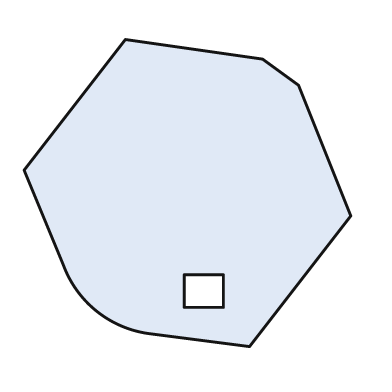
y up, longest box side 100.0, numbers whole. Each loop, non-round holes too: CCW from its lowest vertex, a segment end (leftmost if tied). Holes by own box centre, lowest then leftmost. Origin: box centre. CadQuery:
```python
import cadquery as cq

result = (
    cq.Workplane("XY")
    .moveTo(19.0, -47.0)
    .lineTo(50.0, -7.0)
    .lineTo(34.0, 33.0)
    .lineTo(23.0, 41.0)
    .lineTo(-19.0, 47.0)
    .lineTo(-50.0, 7.0)
    .lineTo(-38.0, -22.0)
    .threePointArc((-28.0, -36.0), (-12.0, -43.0))
    .close()
    .moveTo(-1.0, -35.0)
    .lineTo(11.0, -35.0)
    .lineTo(11.0, -25.0)
    .lineTo(-1.0, -25.0)
    .close()
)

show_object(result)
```